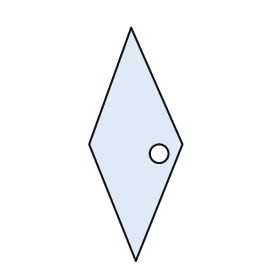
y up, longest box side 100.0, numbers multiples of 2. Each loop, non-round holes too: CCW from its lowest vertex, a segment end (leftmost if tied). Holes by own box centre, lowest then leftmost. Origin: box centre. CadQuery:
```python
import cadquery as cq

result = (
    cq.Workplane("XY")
    .moveTo(0.0, -50.0)
    .lineTo(20.0, 0.0)
    .lineTo(-2.0, 50.0)
    .lineTo(-20.0, 0.0)
    .close()
    .moveTo(10.0, -4.0)
    .circle(4.0)
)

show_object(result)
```